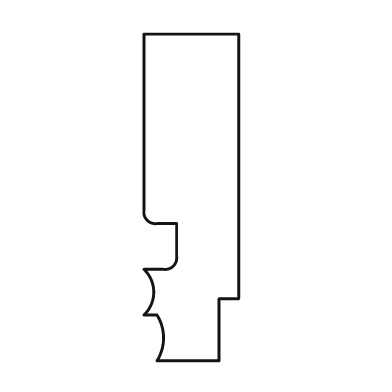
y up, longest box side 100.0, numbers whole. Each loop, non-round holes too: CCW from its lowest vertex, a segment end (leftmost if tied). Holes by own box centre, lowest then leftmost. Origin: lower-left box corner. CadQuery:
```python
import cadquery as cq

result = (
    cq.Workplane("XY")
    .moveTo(4.0, 0.0)
    .lineTo(23.0, 0.0)
    .lineTo(23.0, 19.0)
    .lineTo(29.0, 19.0)
    .lineTo(29.0, 100.0)
    .lineTo(0.0, 100.0)
    .lineTo(0.0, 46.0)
    .threePointArc((1.0, 43.0), (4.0, 42.0))
    .lineTo(10.0, 42.0)
    .lineTo(10.0, 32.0)
    .threePointArc((9.0, 29.0), (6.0, 28.0))
    .lineTo(0.0, 28.0)
    .threePointArc((3.0, 21.0), (0.0, 14.0))
    .lineTo(4.0, 14.0)
    .threePointArc((6.0, 7.0), (4.0, 0.0))
    .close()
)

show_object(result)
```